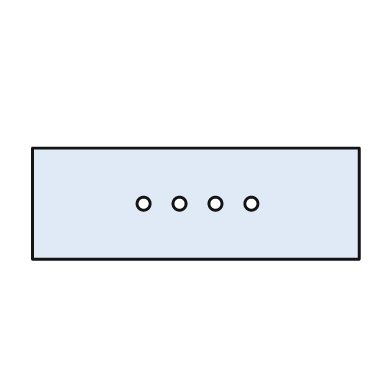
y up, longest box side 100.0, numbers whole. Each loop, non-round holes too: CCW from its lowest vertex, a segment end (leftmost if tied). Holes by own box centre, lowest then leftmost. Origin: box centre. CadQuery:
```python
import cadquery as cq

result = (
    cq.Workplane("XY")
    .moveTo(-50.0, -17.0)
    .lineTo(50.0, -17.0)
    .lineTo(50.0, 17.0)
    .lineTo(-50.0, 17.0)
    .close()
    .moveTo(-16.0, 0.0)
    .circle(2.0)
    .moveTo(-5.0, 0.0)
    .circle(2.0)
    .moveTo(6.0, 0.0)
    .circle(2.0)
    .moveTo(17.0, 0.0)
    .circle(2.0)
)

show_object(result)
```